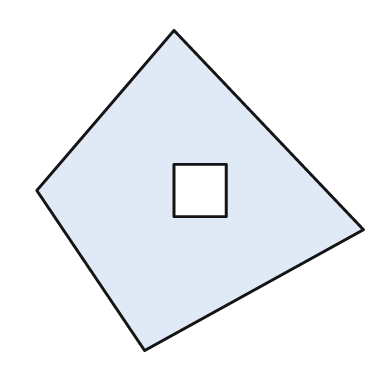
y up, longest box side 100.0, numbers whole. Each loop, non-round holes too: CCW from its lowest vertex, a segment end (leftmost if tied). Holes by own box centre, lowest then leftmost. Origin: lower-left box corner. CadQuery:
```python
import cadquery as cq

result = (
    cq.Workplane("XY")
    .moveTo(33.0, 0.0)
    .lineTo(100.0, 37.0)
    .lineTo(42.0, 98.0)
    .lineTo(0.0, 49.0)
    .close()
    .moveTo(42.0, 41.0)
    .lineTo(58.0, 41.0)
    .lineTo(58.0, 57.0)
    .lineTo(42.0, 57.0)
    .close()
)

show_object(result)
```